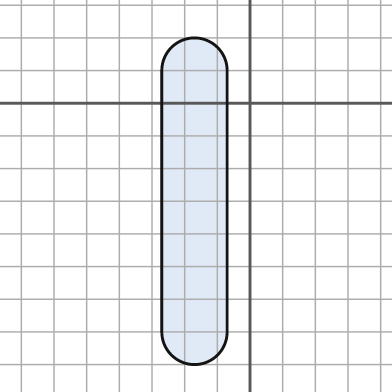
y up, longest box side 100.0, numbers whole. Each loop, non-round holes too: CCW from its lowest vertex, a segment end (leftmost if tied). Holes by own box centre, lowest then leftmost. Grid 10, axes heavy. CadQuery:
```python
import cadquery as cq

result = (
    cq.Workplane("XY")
    .moveTo(-27.0, -70.0)
    .threePointArc((-17.0, -80.0), (-7.0, -70.0))
    .lineTo(-7.0, 10.0)
    .threePointArc((-17.0, 20.0), (-27.0, 10.0))
    .close()
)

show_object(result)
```